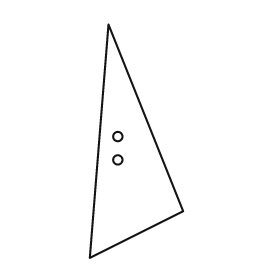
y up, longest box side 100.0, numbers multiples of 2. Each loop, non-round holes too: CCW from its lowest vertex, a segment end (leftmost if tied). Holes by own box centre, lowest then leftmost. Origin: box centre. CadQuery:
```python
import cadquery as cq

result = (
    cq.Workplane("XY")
    .moveTo(-20.0, -50.0)
    .lineTo(20.0, -30.0)
    .lineTo(-12.0, 50.0)
    .close()
    .moveTo(-8.0, -8.0)
    .circle(2.0)
    .moveTo(-8.0, 2.0)
    .circle(2.0)
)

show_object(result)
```